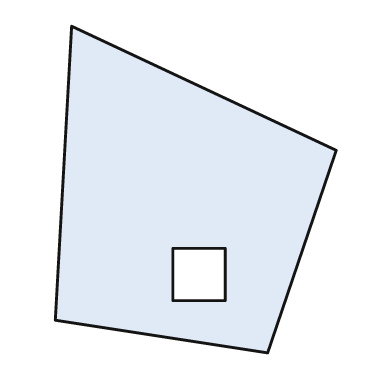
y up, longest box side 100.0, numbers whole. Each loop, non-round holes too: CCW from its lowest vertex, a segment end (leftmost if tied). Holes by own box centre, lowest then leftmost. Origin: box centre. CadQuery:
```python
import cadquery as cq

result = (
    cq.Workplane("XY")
    .moveTo(22.0, -50.0)
    .lineTo(43.0, 12.0)
    .lineTo(-38.0, 50.0)
    .lineTo(-43.0, -40.0)
    .close()
    .moveTo(-7.0, -34.0)
    .lineTo(9.0, -34.0)
    .lineTo(9.0, -18.0)
    .lineTo(-7.0, -18.0)
    .close()
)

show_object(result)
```